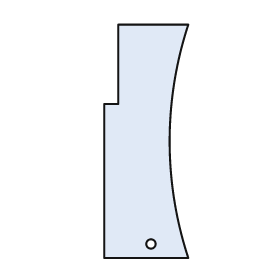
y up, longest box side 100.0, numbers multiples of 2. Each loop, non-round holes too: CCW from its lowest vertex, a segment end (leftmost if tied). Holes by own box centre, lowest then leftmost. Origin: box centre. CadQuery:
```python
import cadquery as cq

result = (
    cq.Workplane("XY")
    .moveTo(-18.0, -50.0)
    .lineTo(18.0, -50.0)
    .threePointArc((10.0, 0.0), (18.0, 50.0))
    .lineTo(-12.0, 50.0)
    .lineTo(-12.0, 16.0)
    .lineTo(-18.0, 16.0)
    .close()
    .moveTo(2.0, -44.0)
    .circle(2.0)
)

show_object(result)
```